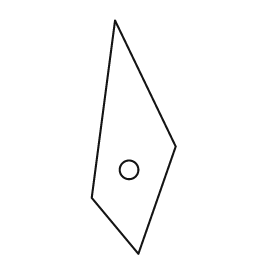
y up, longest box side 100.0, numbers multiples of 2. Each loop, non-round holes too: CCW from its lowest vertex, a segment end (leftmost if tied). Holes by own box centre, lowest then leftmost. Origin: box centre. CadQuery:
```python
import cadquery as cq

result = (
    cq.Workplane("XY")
    .moveTo(2.0, -50.0)
    .lineTo(18.0, -4.0)
    .lineTo(-8.0, 50.0)
    .lineTo(-18.0, -26.0)
    .close()
    .moveTo(-2.0, -14.0)
    .circle(4.0)
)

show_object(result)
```